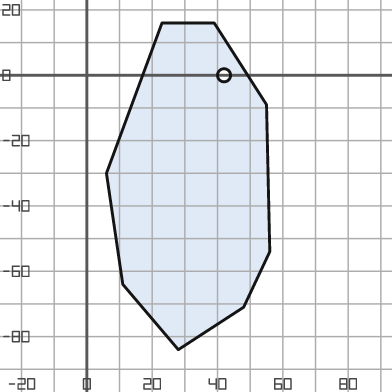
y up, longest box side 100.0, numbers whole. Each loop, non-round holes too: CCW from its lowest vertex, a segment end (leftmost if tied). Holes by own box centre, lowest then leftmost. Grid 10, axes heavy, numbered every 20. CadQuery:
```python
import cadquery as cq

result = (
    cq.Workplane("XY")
    .moveTo(28.0, -84.0)
    .lineTo(48.0, -71.0)
    .lineTo(56.0, -54.0)
    .lineTo(55.0, -9.0)
    .lineTo(39.0, 16.0)
    .lineTo(23.0, 16.0)
    .lineTo(6.0, -30.0)
    .lineTo(11.0, -64.0)
    .close()
    .moveTo(42.0, 0.0)
    .circle(2.0)
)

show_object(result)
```